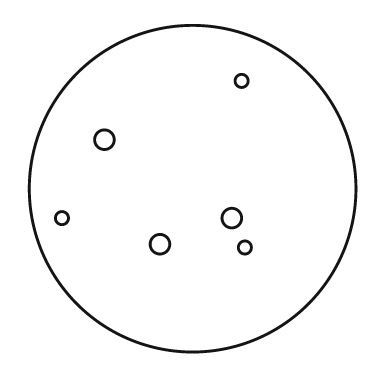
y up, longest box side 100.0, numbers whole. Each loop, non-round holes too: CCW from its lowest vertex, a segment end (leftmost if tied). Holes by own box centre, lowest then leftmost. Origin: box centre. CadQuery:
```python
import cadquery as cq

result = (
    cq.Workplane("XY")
    .moveTo(0.0, 0.0)
    .circle(50.0)
    .moveTo(16.0, -18.0)
    .circle(2.0)
    .moveTo(-10.0, -17.0)
    .circle(3.0)
    .moveTo(-40.0, -9.0)
    .circle(2.0)
    .moveTo(12.0, -9.0)
    .circle(3.0)
    .moveTo(-27.0, 15.0)
    .circle(3.0)
    .moveTo(15.0, 33.0)
    .circle(2.0)
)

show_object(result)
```